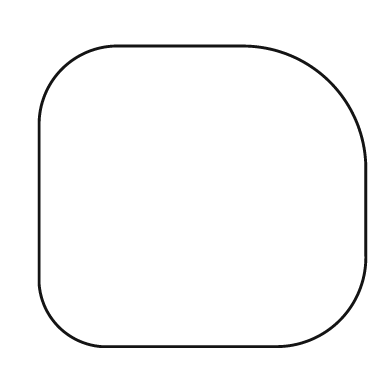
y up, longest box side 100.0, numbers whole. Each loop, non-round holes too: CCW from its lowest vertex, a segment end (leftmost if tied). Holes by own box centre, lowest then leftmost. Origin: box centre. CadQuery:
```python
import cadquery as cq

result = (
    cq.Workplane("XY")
    .moveTo(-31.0, -46.0)
    .lineTo(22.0, -46.0)
    .threePointArc((42.0, -38.0), (50.0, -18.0))
    .lineTo(50.0, 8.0)
    .threePointArc((39.0, 35.0), (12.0, 46.0))
    .lineTo(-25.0, 46.0)
    .threePointArc((-43.0, 39.0), (-50.0, 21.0))
    .lineTo(-50.0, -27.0)
    .threePointArc((-44.0, -40.0), (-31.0, -46.0))
    .close()
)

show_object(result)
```